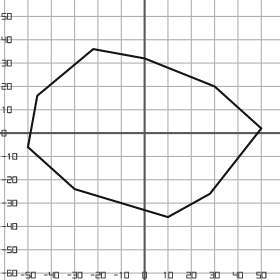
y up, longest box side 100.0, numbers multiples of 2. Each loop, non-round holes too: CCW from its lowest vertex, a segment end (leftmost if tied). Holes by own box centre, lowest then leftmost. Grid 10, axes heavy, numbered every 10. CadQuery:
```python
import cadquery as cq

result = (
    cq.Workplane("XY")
    .moveTo(10.0, -36.0)
    .lineTo(28.0, -26.0)
    .lineTo(50.0, 2.0)
    .lineTo(30.0, 20.0)
    .lineTo(0.0, 32.0)
    .lineTo(-22.0, 36.0)
    .lineTo(-46.0, 16.0)
    .lineTo(-50.0, -6.0)
    .lineTo(-30.0, -24.0)
    .close()
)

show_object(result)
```